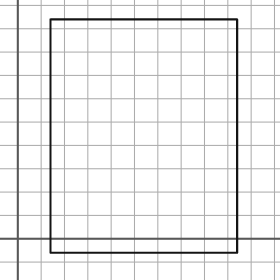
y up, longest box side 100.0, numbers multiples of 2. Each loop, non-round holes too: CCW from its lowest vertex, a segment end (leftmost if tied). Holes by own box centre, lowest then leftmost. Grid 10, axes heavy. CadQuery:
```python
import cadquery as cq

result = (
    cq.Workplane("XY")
    .moveTo(14.0, -6.0)
    .lineTo(94.0, -6.0)
    .lineTo(94.0, 94.0)
    .lineTo(14.0, 94.0)
    .close()
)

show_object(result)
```